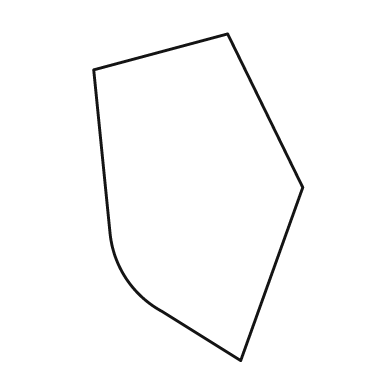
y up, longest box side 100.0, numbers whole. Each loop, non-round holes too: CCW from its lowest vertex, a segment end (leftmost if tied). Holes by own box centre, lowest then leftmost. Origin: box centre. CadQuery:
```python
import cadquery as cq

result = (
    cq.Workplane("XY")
    .moveTo(13.0, -50.0)
    .lineTo(32.0, 3.0)
    .lineTo(9.0, 50.0)
    .lineTo(-32.0, 39.0)
    .lineTo(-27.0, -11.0)
    .threePointArc((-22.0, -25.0), (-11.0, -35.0))
    .close()
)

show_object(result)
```